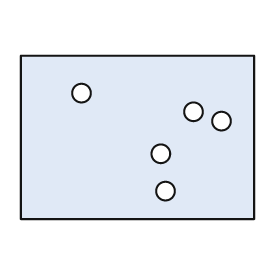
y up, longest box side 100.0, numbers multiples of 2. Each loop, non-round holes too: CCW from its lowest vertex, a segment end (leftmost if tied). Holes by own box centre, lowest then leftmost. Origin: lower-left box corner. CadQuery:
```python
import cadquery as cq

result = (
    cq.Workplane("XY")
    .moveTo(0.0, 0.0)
    .lineTo(100.0, 0.0)
    .lineTo(100.0, 70.0)
    .lineTo(0.0, 70.0)
    .close()
    .moveTo(62.0, 12.0)
    .circle(4.0)
    .moveTo(60.0, 28.0)
    .circle(4.0)
    .moveTo(86.0, 42.0)
    .circle(4.0)
    .moveTo(74.0, 46.0)
    .circle(4.0)
    .moveTo(26.0, 54.0)
    .circle(4.0)
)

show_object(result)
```